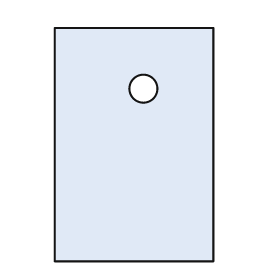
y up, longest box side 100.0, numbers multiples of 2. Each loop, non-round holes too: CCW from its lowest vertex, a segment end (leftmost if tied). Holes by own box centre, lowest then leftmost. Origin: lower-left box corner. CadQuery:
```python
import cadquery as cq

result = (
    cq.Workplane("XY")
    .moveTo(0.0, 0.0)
    .lineTo(68.0, 0.0)
    .lineTo(68.0, 100.0)
    .lineTo(0.0, 100.0)
    .close()
    .moveTo(38.0, 74.0)
    .circle(6.0)
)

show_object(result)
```